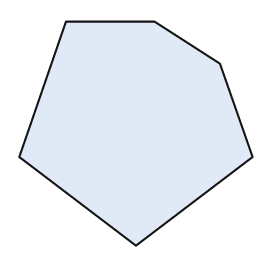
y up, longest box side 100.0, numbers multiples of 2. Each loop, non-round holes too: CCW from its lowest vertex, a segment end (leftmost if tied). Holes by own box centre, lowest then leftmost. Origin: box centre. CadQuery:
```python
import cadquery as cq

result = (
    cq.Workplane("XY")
    .moveTo(0.0, -48.0)
    .lineTo(50.0, -10.0)
    .lineTo(36.0, 30.0)
    .lineTo(8.0, 48.0)
    .lineTo(-30.0, 48.0)
    .lineTo(-50.0, -10.0)
    .close()
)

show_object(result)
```